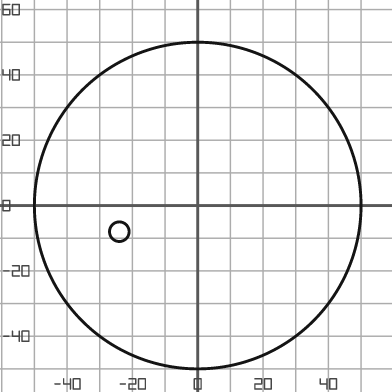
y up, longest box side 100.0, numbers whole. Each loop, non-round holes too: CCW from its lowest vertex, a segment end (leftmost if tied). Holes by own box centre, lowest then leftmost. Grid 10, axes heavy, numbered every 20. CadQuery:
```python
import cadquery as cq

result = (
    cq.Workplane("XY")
    .moveTo(0.0, 0.0)
    .circle(50.0)
    .moveTo(-24.0, -8.0)
    .circle(3.0)
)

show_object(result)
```